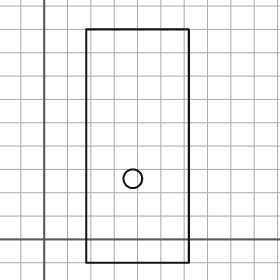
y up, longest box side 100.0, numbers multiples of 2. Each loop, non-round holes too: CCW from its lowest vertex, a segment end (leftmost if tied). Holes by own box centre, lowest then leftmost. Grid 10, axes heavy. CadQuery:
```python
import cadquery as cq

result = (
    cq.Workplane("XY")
    .moveTo(18.0, -10.0)
    .lineTo(62.0, -10.0)
    .lineTo(62.0, 90.0)
    .lineTo(18.0, 90.0)
    .close()
    .moveTo(38.0, 26.0)
    .circle(4.0)
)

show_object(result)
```